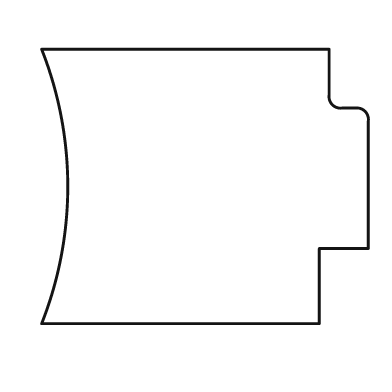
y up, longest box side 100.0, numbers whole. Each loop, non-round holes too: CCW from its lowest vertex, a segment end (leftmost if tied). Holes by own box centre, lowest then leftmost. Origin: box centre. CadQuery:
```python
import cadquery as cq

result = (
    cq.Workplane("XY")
    .moveTo(-50.0, -42.0)
    .lineTo(35.0, -42.0)
    .lineTo(35.0, -19.0)
    .lineTo(50.0, -19.0)
    .lineTo(50.0, 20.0)
    .threePointArc((49.0, 23.0), (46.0, 24.0))
    .lineTo(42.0, 24.0)
    .threePointArc((39.0, 25.0), (38.0, 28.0))
    .lineTo(38.0, 42.0)
    .lineTo(-50.0, 42.0)
    .threePointArc((-42.0, 0.0), (-50.0, -42.0))
    .close()
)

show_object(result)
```